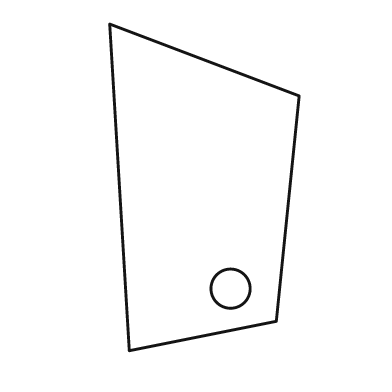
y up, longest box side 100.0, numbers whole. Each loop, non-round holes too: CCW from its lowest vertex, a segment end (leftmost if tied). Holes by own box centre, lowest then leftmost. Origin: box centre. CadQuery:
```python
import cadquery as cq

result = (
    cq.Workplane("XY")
    .moveTo(-23.0, -50.0)
    .lineTo(22.0, -41.0)
    .lineTo(29.0, 28.0)
    .lineTo(-29.0, 50.0)
    .close()
    .moveTo(8.0, -31.0)
    .circle(6.0)
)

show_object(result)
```